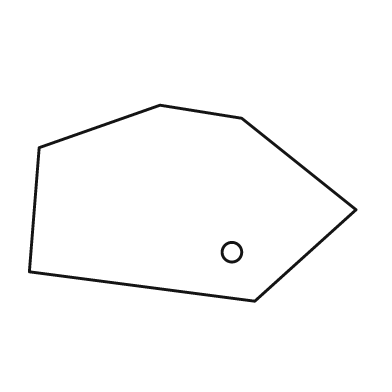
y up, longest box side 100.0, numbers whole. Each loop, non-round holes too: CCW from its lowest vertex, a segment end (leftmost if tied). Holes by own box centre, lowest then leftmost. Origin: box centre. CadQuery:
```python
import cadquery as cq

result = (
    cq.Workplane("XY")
    .moveTo(19.0, -30.0)
    .lineTo(50.0, -2.0)
    .lineTo(15.0, 26.0)
    .lineTo(-10.0, 30.0)
    .lineTo(-47.0, 17.0)
    .lineTo(-50.0, -21.0)
    .close()
    .moveTo(12.0, -15.0)
    .circle(3.0)
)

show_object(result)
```